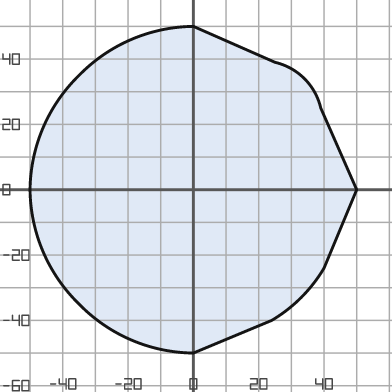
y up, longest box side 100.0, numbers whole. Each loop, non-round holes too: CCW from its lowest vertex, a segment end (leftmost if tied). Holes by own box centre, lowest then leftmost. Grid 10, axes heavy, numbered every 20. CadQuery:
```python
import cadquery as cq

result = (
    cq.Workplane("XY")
    .moveTo(0.0, -50.0)
    .lineTo(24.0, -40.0)
    .threePointArc((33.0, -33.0), (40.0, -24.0))
    .lineTo(50.0, 0.0)
    .lineTo(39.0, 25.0)
    .threePointArc((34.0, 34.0), (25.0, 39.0))
    .lineTo(0.0, 50.0)
    .threePointArc((-19.0, 46.0), (-35.0, 35.0))
    .threePointArc((-46.0, 19.0), (-50.0, 0.0))
    .threePointArc((-46.0, -19.0), (-35.0, -35.0))
    .threePointArc((-19.0, -46.0), (0.0, -50.0))
    .close()
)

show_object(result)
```